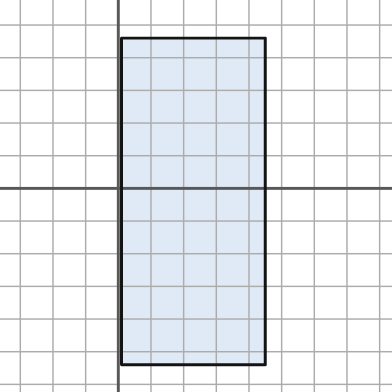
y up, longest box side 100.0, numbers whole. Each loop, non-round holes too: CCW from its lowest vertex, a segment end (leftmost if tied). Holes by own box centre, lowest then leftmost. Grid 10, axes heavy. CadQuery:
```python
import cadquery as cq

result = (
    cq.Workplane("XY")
    .moveTo(1.0, -54.0)
    .lineTo(45.0, -54.0)
    .lineTo(45.0, 46.0)
    .lineTo(1.0, 46.0)
    .close()
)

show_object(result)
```